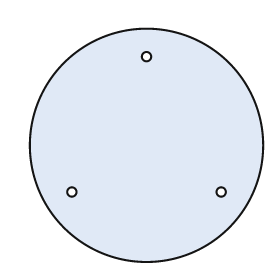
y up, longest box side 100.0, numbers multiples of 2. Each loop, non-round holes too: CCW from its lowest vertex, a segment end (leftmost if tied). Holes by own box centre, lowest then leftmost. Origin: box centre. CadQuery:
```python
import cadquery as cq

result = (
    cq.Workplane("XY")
    .moveTo(0.0, 0.0)
    .circle(50.0)
    .moveTo(-32.0, -20.0)
    .circle(2.0)
    .moveTo(32.0, -20.0)
    .circle(2.0)
    .moveTo(0.0, 38.0)
    .circle(2.0)
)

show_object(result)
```